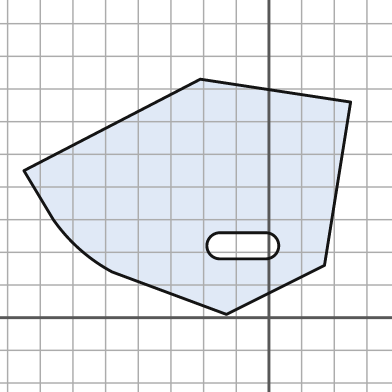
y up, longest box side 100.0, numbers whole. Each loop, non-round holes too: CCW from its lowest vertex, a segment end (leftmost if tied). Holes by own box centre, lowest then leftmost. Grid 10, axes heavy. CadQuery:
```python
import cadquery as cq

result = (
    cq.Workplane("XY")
    .moveTo(-13.0, 1.0)
    .lineTo(17.0, 16.0)
    .lineTo(25.0, 66.0)
    .lineTo(-21.0, 73.0)
    .lineTo(-75.0, 45.0)
    .lineTo(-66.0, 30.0)
    .threePointArc((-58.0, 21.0), (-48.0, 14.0))
    .close()
    .moveTo(-15.0, 18.0)
    .lineTo(-1.0, 18.0)
    .threePointArc((3.0, 22.0), (-1.0, 26.0))
    .lineTo(-15.0, 26.0)
    .threePointArc((-19.0, 22.0), (-15.0, 18.0))
    .close()
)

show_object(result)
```